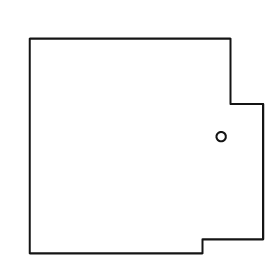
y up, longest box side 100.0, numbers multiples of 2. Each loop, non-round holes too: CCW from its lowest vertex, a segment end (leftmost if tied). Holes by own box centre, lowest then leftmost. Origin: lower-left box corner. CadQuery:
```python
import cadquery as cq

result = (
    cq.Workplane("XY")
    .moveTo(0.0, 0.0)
    .lineTo(74.0, 0.0)
    .lineTo(74.0, 6.0)
    .lineTo(100.0, 6.0)
    .lineTo(100.0, 64.0)
    .lineTo(86.0, 64.0)
    .lineTo(86.0, 92.0)
    .lineTo(0.0, 92.0)
    .close()
    .moveTo(82.0, 50.0)
    .circle(2.0)
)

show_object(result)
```